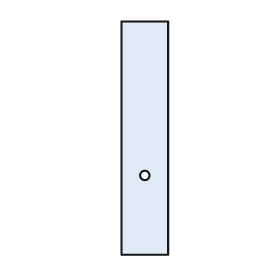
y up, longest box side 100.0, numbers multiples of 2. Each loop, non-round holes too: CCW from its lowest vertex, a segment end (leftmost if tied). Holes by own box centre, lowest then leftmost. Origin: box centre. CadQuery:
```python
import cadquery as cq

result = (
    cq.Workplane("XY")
    .moveTo(-10.0, -50.0)
    .lineTo(10.0, -50.0)
    .lineTo(10.0, 50.0)
    .lineTo(-10.0, 50.0)
    .close()
    .moveTo(0.0, -16.0)
    .circle(2.0)
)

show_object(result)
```